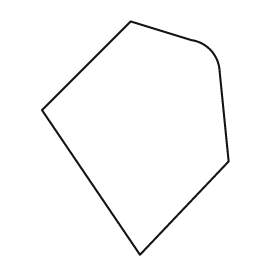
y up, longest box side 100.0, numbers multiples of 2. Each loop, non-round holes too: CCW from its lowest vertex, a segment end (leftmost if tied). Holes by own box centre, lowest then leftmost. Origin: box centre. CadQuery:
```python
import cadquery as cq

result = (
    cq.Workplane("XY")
    .moveTo(2.0, -50.0)
    .lineTo(40.0, -10.0)
    .lineTo(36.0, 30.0)
    .threePointArc((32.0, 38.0), (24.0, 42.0))
    .lineTo(-2.0, 50.0)
    .lineTo(-40.0, 12.0)
    .close()
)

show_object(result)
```